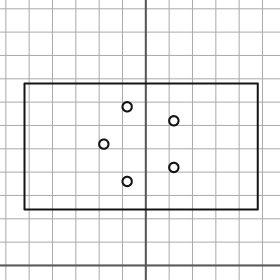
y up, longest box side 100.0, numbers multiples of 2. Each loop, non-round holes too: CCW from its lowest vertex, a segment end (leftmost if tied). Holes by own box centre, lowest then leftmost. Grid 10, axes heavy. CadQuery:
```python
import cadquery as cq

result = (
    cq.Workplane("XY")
    .moveTo(-52.0, 24.0)
    .lineTo(48.0, 24.0)
    .lineTo(48.0, 78.0)
    .lineTo(-52.0, 78.0)
    .close()
    .moveTo(-8.0, 36.0)
    .circle(2.0)
    .moveTo(12.0, 42.0)
    .circle(2.0)
    .moveTo(-18.0, 52.0)
    .circle(2.0)
    .moveTo(12.0, 62.0)
    .circle(2.0)
    .moveTo(-8.0, 68.0)
    .circle(2.0)
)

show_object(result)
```